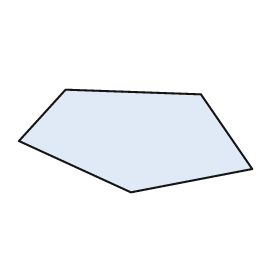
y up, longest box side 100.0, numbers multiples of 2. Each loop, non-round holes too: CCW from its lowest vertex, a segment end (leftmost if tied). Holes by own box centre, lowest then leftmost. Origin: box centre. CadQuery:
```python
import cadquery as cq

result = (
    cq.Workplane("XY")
    .moveTo(-2.0, -22.0)
    .lineTo(50.0, -12.0)
    .lineTo(28.0, 20.0)
    .lineTo(-30.0, 22.0)
    .lineTo(-50.0, 0.0)
    .close()
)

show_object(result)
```